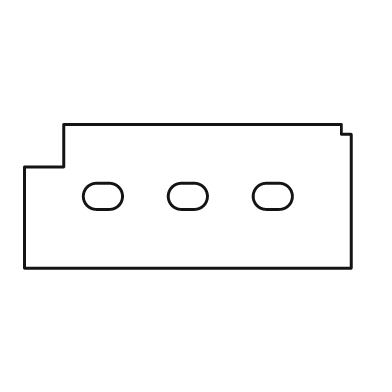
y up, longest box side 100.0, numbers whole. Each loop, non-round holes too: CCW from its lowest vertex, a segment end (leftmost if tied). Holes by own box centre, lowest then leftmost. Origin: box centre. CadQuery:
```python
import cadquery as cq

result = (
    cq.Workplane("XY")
    .moveTo(-50.0, -22.0)
    .lineTo(50.0, -22.0)
    .lineTo(50.0, 19.0)
    .lineTo(47.0, 19.0)
    .lineTo(47.0, 22.0)
    .lineTo(-38.0, 22.0)
    .lineTo(-38.0, 9.0)
    .lineTo(-50.0, 9.0)
    .close()
    .moveTo(-28.0, -4.0)
    .lineTo(-24.0, -4.0)
    .threePointArc((-20.0, 0.0), (-24.0, 4.0))
    .lineTo(-28.0, 4.0)
    .threePointArc((-32.0, 0.0), (-28.0, -4.0))
    .close()
    .moveTo(-2.0, -4.0)
    .lineTo(2.0, -4.0)
    .threePointArc((6.0, 0.0), (2.0, 4.0))
    .lineTo(-2.0, 4.0)
    .threePointArc((-6.0, 0.0), (-2.0, -4.0))
    .close()
    .moveTo(24.0, -4.0)
    .lineTo(28.0, -4.0)
    .threePointArc((32.0, 0.0), (28.0, 4.0))
    .lineTo(24.0, 4.0)
    .threePointArc((20.0, 0.0), (24.0, -4.0))
    .close()
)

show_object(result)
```